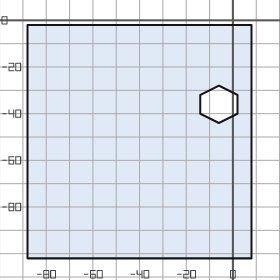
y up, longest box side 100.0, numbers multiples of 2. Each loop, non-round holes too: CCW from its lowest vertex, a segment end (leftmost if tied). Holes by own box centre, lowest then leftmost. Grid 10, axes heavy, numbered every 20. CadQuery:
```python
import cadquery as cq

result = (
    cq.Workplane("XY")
    .moveTo(-88.0, -102.0)
    .lineTo(8.0, -102.0)
    .lineTo(8.0, -2.0)
    .lineTo(-88.0, -2.0)
    .close()
    .moveTo(-6.0, -44.0)
    .lineTo(2.0, -40.0)
    .lineTo(2.0, -32.0)
    .lineTo(-6.0, -28.0)
    .lineTo(-14.0, -32.0)
    .lineTo(-14.0, -40.0)
    .close()
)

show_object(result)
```